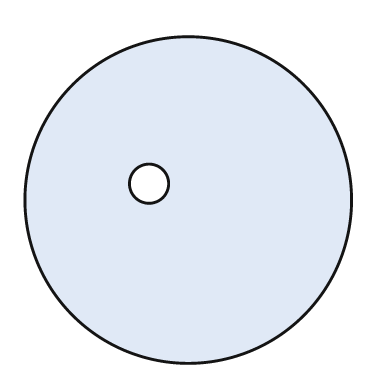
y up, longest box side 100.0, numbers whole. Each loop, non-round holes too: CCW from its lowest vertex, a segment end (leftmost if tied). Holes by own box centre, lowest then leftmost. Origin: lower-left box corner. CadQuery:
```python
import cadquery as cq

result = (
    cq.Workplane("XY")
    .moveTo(50.0, 50.0)
    .circle(50.0)
    .moveTo(38.0, 55.0)
    .circle(6.0)
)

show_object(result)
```